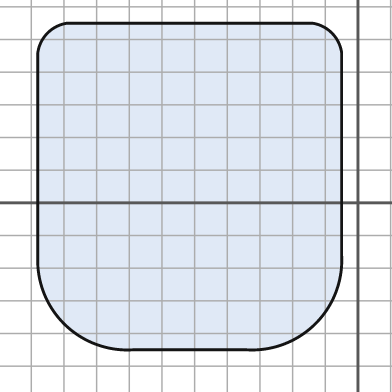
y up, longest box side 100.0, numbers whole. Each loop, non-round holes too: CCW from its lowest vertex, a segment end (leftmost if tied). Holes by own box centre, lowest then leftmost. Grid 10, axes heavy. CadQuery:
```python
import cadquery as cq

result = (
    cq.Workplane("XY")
    .moveTo(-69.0, -45.0)
    .lineTo(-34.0, -45.0)
    .threePointArc((-13.0, -37.0), (-5.0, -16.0))
    .lineTo(-5.0, 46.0)
    .threePointArc((-8.0, 52.0), (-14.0, 55.0))
    .lineTo(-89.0, 55.0)
    .threePointArc((-95.0, 52.0), (-98.0, 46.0))
    .lineTo(-98.0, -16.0)
    .threePointArc((-90.0, -37.0), (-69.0, -45.0))
    .close()
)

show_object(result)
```